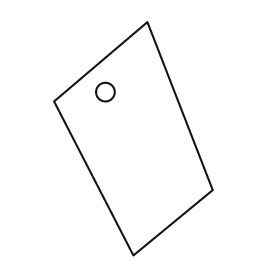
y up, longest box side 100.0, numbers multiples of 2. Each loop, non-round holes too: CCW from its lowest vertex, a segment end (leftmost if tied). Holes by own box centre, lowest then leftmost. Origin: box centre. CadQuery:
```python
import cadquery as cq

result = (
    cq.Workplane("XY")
    .moveTo(0.0, -50.0)
    .lineTo(34.0, -22.0)
    .lineTo(6.0, 50.0)
    .lineTo(-34.0, 16.0)
    .close()
    .moveTo(-12.0, 20.0)
    .circle(4.0)
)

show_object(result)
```